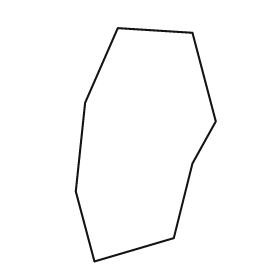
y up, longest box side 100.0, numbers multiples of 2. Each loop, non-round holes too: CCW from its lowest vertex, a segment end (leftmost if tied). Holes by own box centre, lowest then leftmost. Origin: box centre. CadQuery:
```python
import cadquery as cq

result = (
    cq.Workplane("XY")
    .moveTo(-22.0, -50.0)
    .lineTo(12.0, -40.0)
    .lineTo(20.0, -8.0)
    .lineTo(30.0, 10.0)
    .lineTo(20.0, 48.0)
    .lineTo(-12.0, 50.0)
    .lineTo(-26.0, 18.0)
    .lineTo(-30.0, -20.0)
    .close()
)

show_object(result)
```